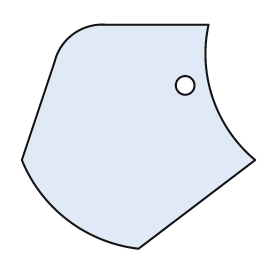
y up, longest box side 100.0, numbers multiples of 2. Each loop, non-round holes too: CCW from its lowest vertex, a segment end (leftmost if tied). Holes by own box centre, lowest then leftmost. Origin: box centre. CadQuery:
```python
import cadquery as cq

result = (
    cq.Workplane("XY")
    .moveTo(0.0, -48.0)
    .lineTo(50.0, -10.0)
    .threePointArc((32.0, 16.0), (30.0, 48.0))
    .lineTo(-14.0, 48.0)
    .threePointArc((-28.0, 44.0), (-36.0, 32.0))
    .lineTo(-50.0, -10.0)
    .threePointArc((-30.0, -36.0), (0.0, -48.0))
    .close()
    .moveTo(20.0, 22.0)
    .circle(4.0)
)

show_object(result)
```